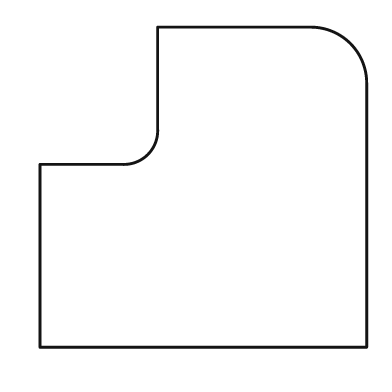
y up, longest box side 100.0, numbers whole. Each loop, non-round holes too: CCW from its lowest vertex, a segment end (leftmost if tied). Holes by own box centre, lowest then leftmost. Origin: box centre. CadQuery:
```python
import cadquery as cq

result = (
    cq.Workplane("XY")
    .moveTo(-50.0, -49.0)
    .lineTo(50.0, -49.0)
    .lineTo(50.0, 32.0)
    .threePointArc((45.0, 44.0), (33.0, 49.0))
    .lineTo(-14.0, 49.0)
    .lineTo(-14.0, 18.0)
    .threePointArc((-17.0, 10.0), (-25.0, 7.0))
    .lineTo(-50.0, 7.0)
    .close()
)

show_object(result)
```